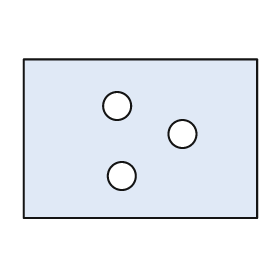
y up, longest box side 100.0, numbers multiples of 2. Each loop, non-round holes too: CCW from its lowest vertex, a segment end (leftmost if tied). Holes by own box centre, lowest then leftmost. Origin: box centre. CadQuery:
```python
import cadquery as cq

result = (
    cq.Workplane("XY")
    .moveTo(-50.0, -34.0)
    .lineTo(50.0, -34.0)
    .lineTo(50.0, 34.0)
    .lineTo(-50.0, 34.0)
    .close()
    .moveTo(-8.0, -16.0)
    .circle(6.0)
    .moveTo(18.0, 2.0)
    .circle(6.0)
    .moveTo(-10.0, 14.0)
    .circle(6.0)
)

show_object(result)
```